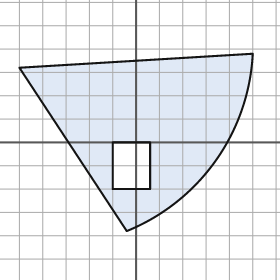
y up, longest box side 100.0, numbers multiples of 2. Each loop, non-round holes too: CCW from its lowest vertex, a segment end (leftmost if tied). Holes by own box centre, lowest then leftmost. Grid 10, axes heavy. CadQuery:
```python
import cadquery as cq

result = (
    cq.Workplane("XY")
    .moveTo(-4.0, -38.0)
    .threePointArc((34.0, -8.0), (50.0, 38.0))
    .lineTo(-50.0, 32.0)
    .close()
    .moveTo(-10.0, -20.0)
    .lineTo(6.0, -20.0)
    .lineTo(6.0, 0.0)
    .lineTo(-10.0, 0.0)
    .close()
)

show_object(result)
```